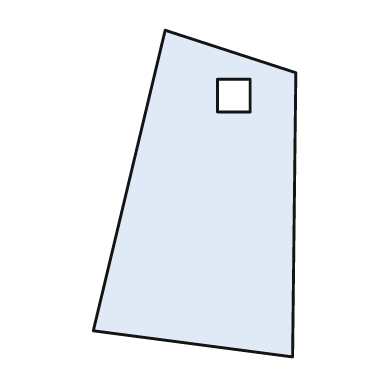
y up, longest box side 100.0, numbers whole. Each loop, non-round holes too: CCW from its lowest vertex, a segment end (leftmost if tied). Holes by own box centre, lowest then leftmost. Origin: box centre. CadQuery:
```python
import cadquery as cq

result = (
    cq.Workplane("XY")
    .moveTo(30.0, -50.0)
    .lineTo(31.0, 37.0)
    .lineTo(-9.0, 50.0)
    .lineTo(-31.0, -42.0)
    .close()
    .moveTo(7.0, 25.0)
    .lineTo(17.0, 25.0)
    .lineTo(17.0, 35.0)
    .lineTo(7.0, 35.0)
    .close()
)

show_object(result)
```